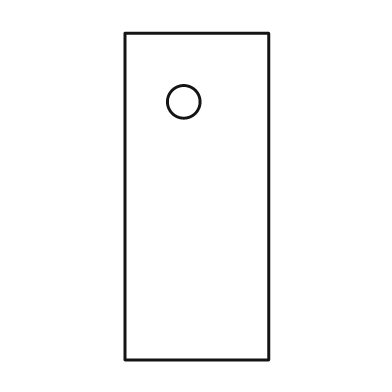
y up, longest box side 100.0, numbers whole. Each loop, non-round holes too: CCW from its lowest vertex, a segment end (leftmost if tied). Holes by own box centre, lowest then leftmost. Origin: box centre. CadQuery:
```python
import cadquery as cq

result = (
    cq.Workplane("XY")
    .moveTo(-22.0, -50.0)
    .lineTo(22.0, -50.0)
    .lineTo(22.0, 50.0)
    .lineTo(-22.0, 50.0)
    .close()
    .moveTo(-4.0, 29.0)
    .circle(5.0)
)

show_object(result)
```